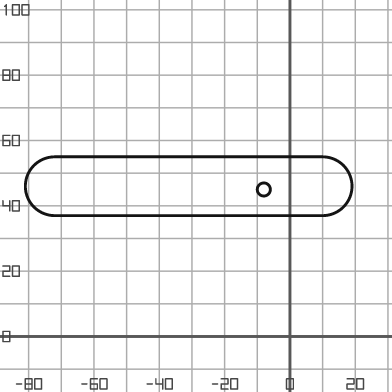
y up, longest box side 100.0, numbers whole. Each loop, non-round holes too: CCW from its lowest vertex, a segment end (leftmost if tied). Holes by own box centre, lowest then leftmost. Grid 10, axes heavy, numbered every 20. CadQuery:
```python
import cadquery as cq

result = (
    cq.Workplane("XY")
    .moveTo(-72.0, 37.0)
    .lineTo(10.0, 37.0)
    .threePointArc((19.0, 46.0), (10.0, 55.0))
    .lineTo(-72.0, 55.0)
    .threePointArc((-81.0, 46.0), (-72.0, 37.0))
    .close()
    .moveTo(-8.0, 45.0)
    .circle(2.0)
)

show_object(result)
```